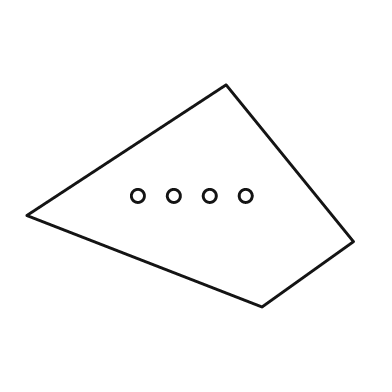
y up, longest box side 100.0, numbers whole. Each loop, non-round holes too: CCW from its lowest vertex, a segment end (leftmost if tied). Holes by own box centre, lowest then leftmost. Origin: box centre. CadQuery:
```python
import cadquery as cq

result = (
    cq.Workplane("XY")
    .moveTo(22.0, -34.0)
    .lineTo(50.0, -14.0)
    .lineTo(11.0, 34.0)
    .lineTo(-50.0, -6.0)
    .close()
    .moveTo(-16.0, 0.0)
    .circle(2.0)
    .moveTo(-5.0, 0.0)
    .circle(2.0)
    .moveTo(6.0, 0.0)
    .circle(2.0)
    .moveTo(17.0, 0.0)
    .circle(2.0)
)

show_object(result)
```